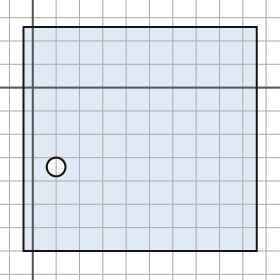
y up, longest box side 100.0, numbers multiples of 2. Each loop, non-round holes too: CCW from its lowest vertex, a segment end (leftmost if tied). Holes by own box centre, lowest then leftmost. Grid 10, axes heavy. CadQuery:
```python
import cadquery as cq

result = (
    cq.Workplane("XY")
    .moveTo(-4.0, -70.0)
    .lineTo(96.0, -70.0)
    .lineTo(96.0, 26.0)
    .lineTo(-4.0, 26.0)
    .close()
    .moveTo(10.0, -34.0)
    .circle(4.0)
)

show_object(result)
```